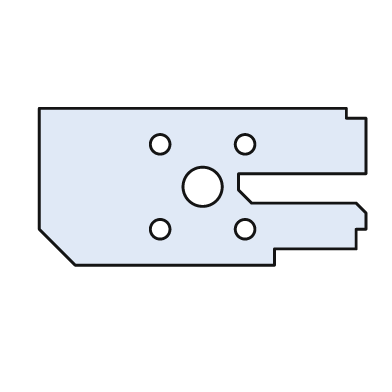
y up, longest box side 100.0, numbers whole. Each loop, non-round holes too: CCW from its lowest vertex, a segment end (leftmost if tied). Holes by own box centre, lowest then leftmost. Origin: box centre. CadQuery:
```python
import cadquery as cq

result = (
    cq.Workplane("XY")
    .moveTo(-39.0, -24.0)
    .lineTo(22.0, -24.0)
    .lineTo(22.0, -19.0)
    .lineTo(47.0, -19.0)
    .lineTo(47.0, -13.0)
    .lineTo(50.0, -13.0)
    .lineTo(50.0, -8.0)
    .lineTo(47.0, -5.0)
    .lineTo(15.0, -5.0)
    .lineTo(11.0, -1.0)
    .lineTo(11.0, 4.0)
    .lineTo(50.0, 4.0)
    .lineTo(50.0, 21.0)
    .lineTo(44.0, 21.0)
    .lineTo(44.0, 24.0)
    .lineTo(-50.0, 24.0)
    .lineTo(-50.0, -13.0)
    .close()
    .moveTo(-13.0, -13.0)
    .circle(3.0)
    .moveTo(13.0, -13.0)
    .circle(3.0)
    .moveTo(0.0, 0.0)
    .circle(6.0)
    .moveTo(-13.0, 13.0)
    .circle(3.0)
    .moveTo(13.0, 13.0)
    .circle(3.0)
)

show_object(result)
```